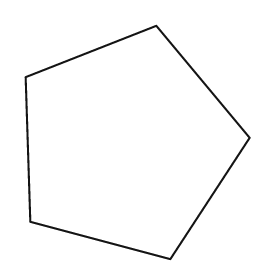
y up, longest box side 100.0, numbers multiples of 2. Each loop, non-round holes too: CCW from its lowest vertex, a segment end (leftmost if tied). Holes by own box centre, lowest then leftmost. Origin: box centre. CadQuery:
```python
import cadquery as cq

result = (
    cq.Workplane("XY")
    .moveTo(14.0, -50.0)
    .lineTo(48.0, 2.0)
    .lineTo(8.0, 50.0)
    .lineTo(-48.0, 28.0)
    .lineTo(-46.0, -34.0)
    .close()
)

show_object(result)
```